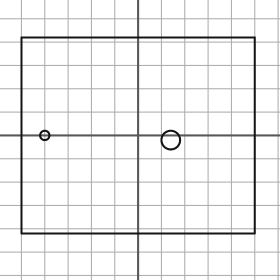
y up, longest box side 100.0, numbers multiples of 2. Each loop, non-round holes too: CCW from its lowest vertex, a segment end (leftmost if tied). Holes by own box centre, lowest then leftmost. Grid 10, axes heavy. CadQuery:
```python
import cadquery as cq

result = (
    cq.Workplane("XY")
    .moveTo(-50.0, -42.0)
    .lineTo(50.0, -42.0)
    .lineTo(50.0, 42.0)
    .lineTo(-50.0, 42.0)
    .close()
    .moveTo(14.0, -2.0)
    .circle(4.0)
    .moveTo(-40.0, 0.0)
    .circle(2.0)
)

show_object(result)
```